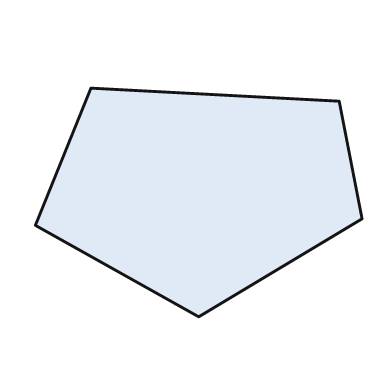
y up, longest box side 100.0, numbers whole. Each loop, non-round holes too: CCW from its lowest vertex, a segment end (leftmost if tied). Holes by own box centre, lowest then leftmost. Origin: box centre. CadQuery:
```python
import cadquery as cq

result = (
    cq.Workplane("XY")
    .moveTo(0.0, -35.0)
    .lineTo(50.0, -5.0)
    .lineTo(43.0, 31.0)
    .lineTo(-33.0, 35.0)
    .lineTo(-50.0, -7.0)
    .close()
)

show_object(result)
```